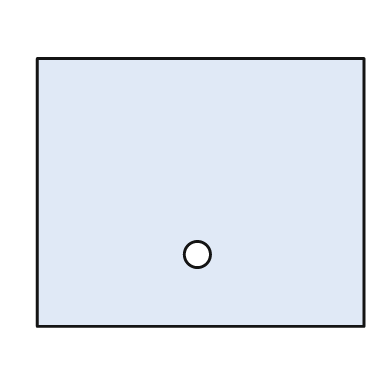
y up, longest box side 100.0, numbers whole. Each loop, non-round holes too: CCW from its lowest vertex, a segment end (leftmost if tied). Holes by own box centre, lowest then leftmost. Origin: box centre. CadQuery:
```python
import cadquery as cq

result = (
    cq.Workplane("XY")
    .moveTo(-50.0, -41.0)
    .lineTo(50.0, -41.0)
    .lineTo(50.0, 41.0)
    .lineTo(-50.0, 41.0)
    .close()
    .moveTo(-1.0, -19.0)
    .circle(4.0)
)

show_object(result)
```